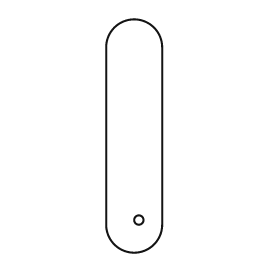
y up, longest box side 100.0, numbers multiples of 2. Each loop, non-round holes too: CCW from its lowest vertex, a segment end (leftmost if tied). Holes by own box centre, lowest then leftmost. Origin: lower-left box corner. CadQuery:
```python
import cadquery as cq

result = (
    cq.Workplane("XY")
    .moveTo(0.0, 12.0)
    .threePointArc((12.0, 0.0), (24.0, 12.0))
    .lineTo(24.0, 88.0)
    .threePointArc((12.0, 100.0), (0.0, 88.0))
    .close()
    .moveTo(14.0, 14.0)
    .circle(2.0)
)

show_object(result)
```